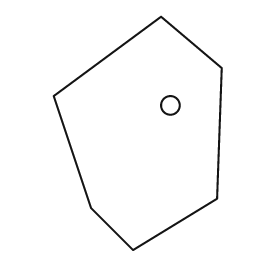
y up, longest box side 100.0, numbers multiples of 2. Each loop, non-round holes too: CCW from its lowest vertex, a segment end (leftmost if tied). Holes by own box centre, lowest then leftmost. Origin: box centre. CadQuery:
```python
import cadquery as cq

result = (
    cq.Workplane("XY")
    .moveTo(-2.0, -50.0)
    .lineTo(34.0, -28.0)
    .lineTo(36.0, 28.0)
    .lineTo(10.0, 50.0)
    .lineTo(-36.0, 16.0)
    .lineTo(-20.0, -32.0)
    .close()
    .moveTo(14.0, 12.0)
    .circle(4.0)
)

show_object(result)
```